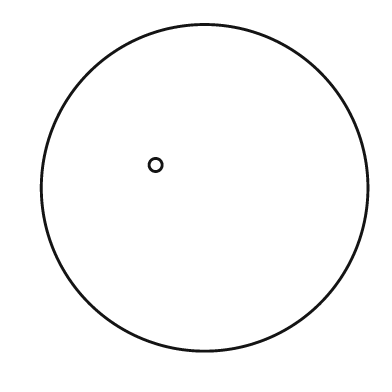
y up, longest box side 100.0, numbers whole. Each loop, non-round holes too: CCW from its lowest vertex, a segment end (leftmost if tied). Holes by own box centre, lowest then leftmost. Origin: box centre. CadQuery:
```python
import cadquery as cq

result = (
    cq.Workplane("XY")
    .moveTo(0.0, 0.0)
    .circle(50.0)
    .moveTo(-15.0, 7.0)
    .circle(2.0)
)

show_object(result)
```